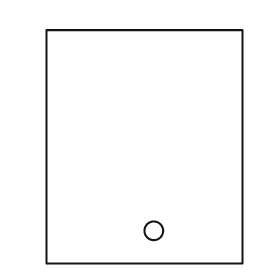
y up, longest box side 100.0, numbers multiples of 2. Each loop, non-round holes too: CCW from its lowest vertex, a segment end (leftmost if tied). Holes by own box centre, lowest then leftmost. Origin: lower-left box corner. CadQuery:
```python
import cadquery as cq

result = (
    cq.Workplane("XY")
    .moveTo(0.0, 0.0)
    .lineTo(84.0, 0.0)
    .lineTo(84.0, 100.0)
    .lineTo(0.0, 100.0)
    .close()
    .moveTo(46.0, 14.0)
    .circle(4.0)
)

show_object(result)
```